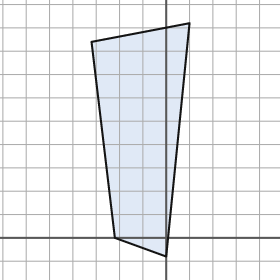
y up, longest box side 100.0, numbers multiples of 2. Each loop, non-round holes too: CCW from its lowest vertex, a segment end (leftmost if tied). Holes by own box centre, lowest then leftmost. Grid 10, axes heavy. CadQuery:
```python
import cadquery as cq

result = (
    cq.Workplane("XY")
    .moveTo(0.0, -8.0)
    .lineTo(10.0, 92.0)
    .lineTo(-32.0, 84.0)
    .lineTo(-22.0, 0.0)
    .close()
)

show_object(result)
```